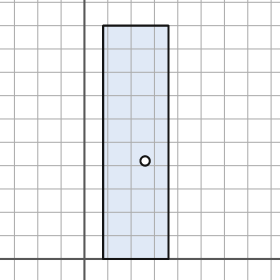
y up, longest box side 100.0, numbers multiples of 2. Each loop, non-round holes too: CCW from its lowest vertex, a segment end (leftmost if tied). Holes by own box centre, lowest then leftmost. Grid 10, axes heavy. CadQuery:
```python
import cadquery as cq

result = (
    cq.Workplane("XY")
    .moveTo(8.0, 0.0)
    .lineTo(36.0, 0.0)
    .lineTo(36.0, 100.0)
    .lineTo(8.0, 100.0)
    .close()
    .moveTo(26.0, 42.0)
    .circle(2.0)
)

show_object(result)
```